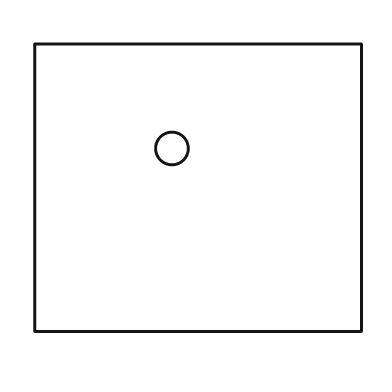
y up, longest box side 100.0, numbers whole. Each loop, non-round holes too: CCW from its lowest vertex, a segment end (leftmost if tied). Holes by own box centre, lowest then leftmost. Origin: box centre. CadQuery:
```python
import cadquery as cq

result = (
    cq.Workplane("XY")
    .moveTo(-50.0, -44.0)
    .lineTo(50.0, -44.0)
    .lineTo(50.0, 44.0)
    .lineTo(-50.0, 44.0)
    .close()
    .moveTo(-8.0, 12.0)
    .circle(5.0)
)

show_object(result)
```